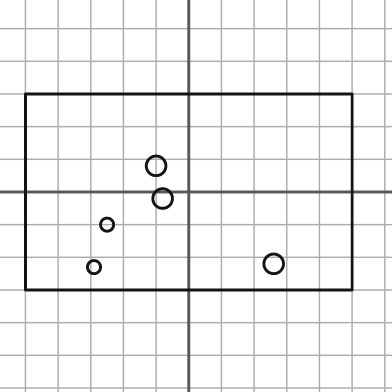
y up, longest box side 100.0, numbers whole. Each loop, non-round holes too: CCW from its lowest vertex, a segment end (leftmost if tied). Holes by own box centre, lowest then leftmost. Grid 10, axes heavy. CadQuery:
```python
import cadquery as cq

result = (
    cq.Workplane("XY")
    .moveTo(-50.0, -30.0)
    .lineTo(50.0, -30.0)
    .lineTo(50.0, 30.0)
    .lineTo(-50.0, 30.0)
    .close()
    .moveTo(-29.0, -23.0)
    .circle(2.0)
    .moveTo(26.0, -22.0)
    .circle(3.0)
    .moveTo(-25.0, -10.0)
    .circle(2.0)
    .moveTo(-8.0, -2.0)
    .circle(3.0)
    .moveTo(-10.0, 8.0)
    .circle(3.0)
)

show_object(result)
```